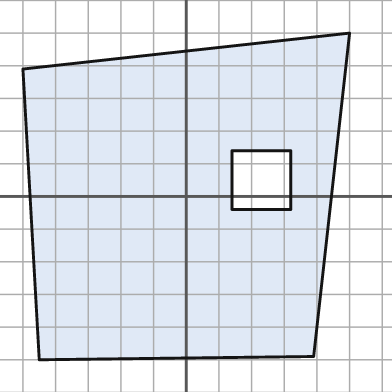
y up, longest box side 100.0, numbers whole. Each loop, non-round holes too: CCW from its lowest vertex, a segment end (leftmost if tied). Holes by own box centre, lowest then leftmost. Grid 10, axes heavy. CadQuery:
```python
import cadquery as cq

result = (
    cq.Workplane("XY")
    .moveTo(-45.0, -50.0)
    .lineTo(39.0, -49.0)
    .lineTo(50.0, 50.0)
    .lineTo(-50.0, 39.0)
    .close()
    .moveTo(14.0, -4.0)
    .lineTo(32.0, -4.0)
    .lineTo(32.0, 14.0)
    .lineTo(14.0, 14.0)
    .close()
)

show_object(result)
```